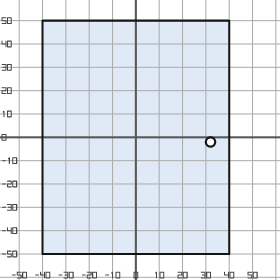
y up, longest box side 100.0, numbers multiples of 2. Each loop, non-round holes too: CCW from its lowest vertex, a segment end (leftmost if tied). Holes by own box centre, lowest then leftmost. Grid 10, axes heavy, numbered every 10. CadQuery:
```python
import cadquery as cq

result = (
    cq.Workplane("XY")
    .moveTo(-40.0, -50.0)
    .lineTo(40.0, -50.0)
    .lineTo(40.0, 50.0)
    .lineTo(-40.0, 50.0)
    .close()
    .moveTo(32.0, -2.0)
    .circle(2.0)
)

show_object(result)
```